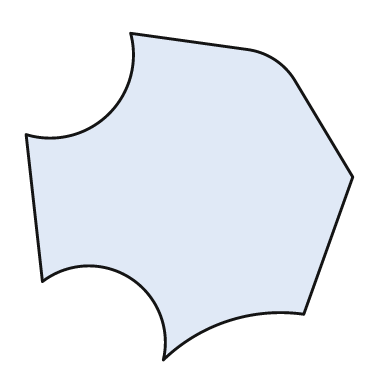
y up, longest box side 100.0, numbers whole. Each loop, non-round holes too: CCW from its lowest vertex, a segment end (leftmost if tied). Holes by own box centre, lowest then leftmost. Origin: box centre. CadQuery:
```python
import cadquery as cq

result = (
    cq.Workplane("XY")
    .moveTo(-8.0, -50.0)
    .threePointArc((12.0, -38.0), (35.0, -36.0))
    .lineTo(50.0, 6.0)
    .lineTo(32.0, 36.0)
    .threePointArc((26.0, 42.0), (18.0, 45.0))
    .lineTo(-18.0, 50.0)
    .threePointArc((-25.0, 25.0), (-50.0, 19.0))
    .lineTo(-45.0, -26.0)
    .threePointArc((-18.0, -25.0), (-8.0, -50.0))
    .close()
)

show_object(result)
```